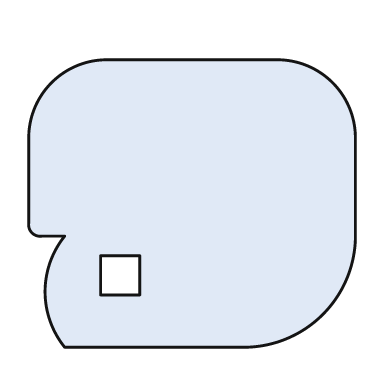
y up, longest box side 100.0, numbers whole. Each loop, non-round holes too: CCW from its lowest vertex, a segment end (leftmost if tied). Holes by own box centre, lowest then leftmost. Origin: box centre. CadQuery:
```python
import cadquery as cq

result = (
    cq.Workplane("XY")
    .moveTo(-39.0, -44.0)
    .lineTo(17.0, -44.0)
    .threePointArc((40.0, -34.0), (50.0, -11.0))
    .lineTo(50.0, 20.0)
    .threePointArc((43.0, 37.0), (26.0, 44.0))
    .lineTo(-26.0, 44.0)
    .threePointArc((-43.0, 37.0), (-50.0, 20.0))
    .lineTo(-50.0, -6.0)
    .threePointArc((-49.0, -9.0), (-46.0, -10.0))
    .lineTo(-39.0, -10.0)
    .threePointArc((-45.0, -27.0), (-39.0, -44.0))
    .close()
    .moveTo(-28.0, -28.0)
    .lineTo(-16.0, -28.0)
    .lineTo(-16.0, -16.0)
    .lineTo(-28.0, -16.0)
    .close()
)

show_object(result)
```